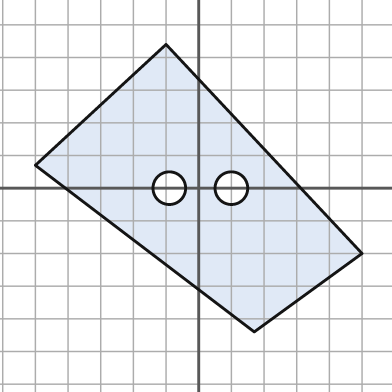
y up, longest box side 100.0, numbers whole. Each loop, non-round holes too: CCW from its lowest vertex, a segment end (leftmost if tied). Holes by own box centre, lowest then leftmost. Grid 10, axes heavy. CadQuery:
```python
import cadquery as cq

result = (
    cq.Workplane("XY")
    .moveTo(17.0, -44.0)
    .lineTo(50.0, -20.0)
    .lineTo(-10.0, 44.0)
    .lineTo(-50.0, 7.0)
    .close()
    .moveTo(-9.0, 0.0)
    .circle(5.0)
    .moveTo(10.0, 0.0)
    .circle(5.0)
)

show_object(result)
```